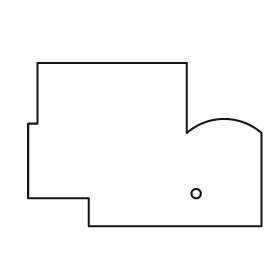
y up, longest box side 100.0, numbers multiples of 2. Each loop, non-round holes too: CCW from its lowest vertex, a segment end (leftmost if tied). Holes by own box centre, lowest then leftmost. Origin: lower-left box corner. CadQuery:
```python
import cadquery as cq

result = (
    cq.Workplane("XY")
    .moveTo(26.0, 0.0)
    .lineTo(100.0, 0.0)
    .lineTo(100.0, 40.0)
    .threePointArc((84.0, 46.0), (68.0, 40.0))
    .lineTo(68.0, 70.0)
    .lineTo(4.0, 70.0)
    .lineTo(4.0, 44.0)
    .lineTo(0.0, 44.0)
    .lineTo(0.0, 12.0)
    .lineTo(26.0, 12.0)
    .close()
    .moveTo(72.0, 14.0)
    .circle(2.0)
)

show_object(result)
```